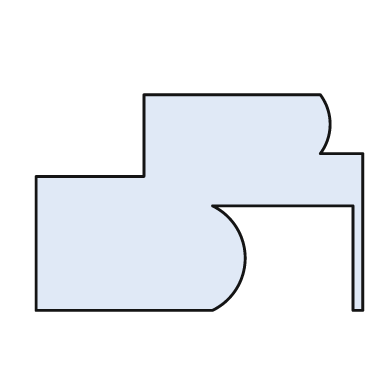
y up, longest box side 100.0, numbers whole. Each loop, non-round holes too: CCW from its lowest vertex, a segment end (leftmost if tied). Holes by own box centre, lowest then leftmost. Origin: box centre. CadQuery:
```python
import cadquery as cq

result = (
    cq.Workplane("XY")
    .moveTo(-50.0, -33.0)
    .lineTo(4.0, -33.0)
    .threePointArc((14.0, -17.0), (4.0, -1.0))
    .lineTo(47.0, -1.0)
    .lineTo(47.0, -33.0)
    .lineTo(50.0, -33.0)
    .lineTo(50.0, 15.0)
    .lineTo(37.0, 15.0)
    .threePointArc((40.0, 24.0), (37.0, 33.0))
    .lineTo(-17.0, 33.0)
    .lineTo(-17.0, 8.0)
    .lineTo(-50.0, 8.0)
    .close()
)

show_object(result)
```